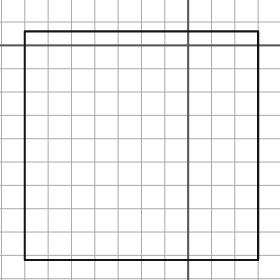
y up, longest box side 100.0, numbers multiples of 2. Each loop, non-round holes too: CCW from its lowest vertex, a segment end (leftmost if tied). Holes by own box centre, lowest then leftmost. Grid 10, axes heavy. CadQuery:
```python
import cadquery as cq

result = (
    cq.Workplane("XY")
    .moveTo(-70.0, -92.0)
    .lineTo(30.0, -92.0)
    .lineTo(30.0, 6.0)
    .lineTo(-70.0, 6.0)
    .close()
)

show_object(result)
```